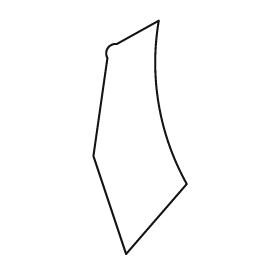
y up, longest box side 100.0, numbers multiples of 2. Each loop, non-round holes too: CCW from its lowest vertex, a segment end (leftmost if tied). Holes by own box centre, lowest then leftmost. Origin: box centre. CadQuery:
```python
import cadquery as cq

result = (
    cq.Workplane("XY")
    .moveTo(-6.0, -50.0)
    .lineTo(20.0, -20.0)
    .threePointArc((8.0, 14.0), (8.0, 50.0))
    .lineTo(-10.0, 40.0)
    .threePointArc((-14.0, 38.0), (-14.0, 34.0))
    .lineTo(-20.0, -8.0)
    .close()
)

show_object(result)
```